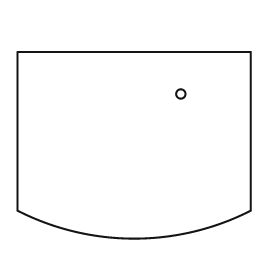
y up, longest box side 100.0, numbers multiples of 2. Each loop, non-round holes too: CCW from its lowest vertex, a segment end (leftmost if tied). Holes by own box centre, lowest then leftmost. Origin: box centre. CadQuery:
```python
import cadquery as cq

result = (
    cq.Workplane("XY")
    .moveTo(-50.0, -28.0)
    .threePointArc((0.0, -40.0), (50.0, -28.0))
    .lineTo(50.0, 40.0)
    .lineTo(-50.0, 40.0)
    .close()
    .moveTo(20.0, 22.0)
    .circle(2.0)
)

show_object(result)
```